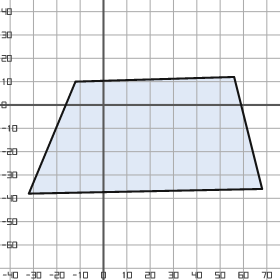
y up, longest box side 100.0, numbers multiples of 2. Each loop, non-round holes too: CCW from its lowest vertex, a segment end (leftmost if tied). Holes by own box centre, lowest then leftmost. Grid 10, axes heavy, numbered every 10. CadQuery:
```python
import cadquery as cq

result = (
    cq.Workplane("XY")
    .moveTo(-32.0, -38.0)
    .lineTo(68.0, -36.0)
    .lineTo(56.0, 12.0)
    .lineTo(-12.0, 10.0)
    .close()
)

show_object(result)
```